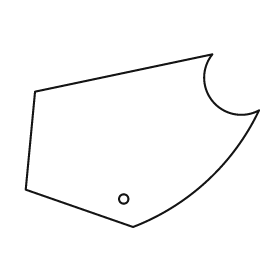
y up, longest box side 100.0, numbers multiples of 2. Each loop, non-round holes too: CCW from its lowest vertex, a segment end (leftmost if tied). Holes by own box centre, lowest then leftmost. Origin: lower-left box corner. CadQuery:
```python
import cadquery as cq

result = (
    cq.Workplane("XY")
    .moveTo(46.0, 0.0)
    .threePointArc((78.0, 20.0), (100.0, 50.0))
    .threePointArc((80.0, 54.0), (80.0, 74.0))
    .lineTo(4.0, 58.0)
    .lineTo(0.0, 16.0)
    .close()
    .moveTo(42.0, 12.0)
    .circle(2.0)
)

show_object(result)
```